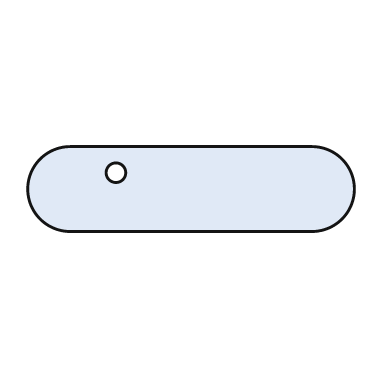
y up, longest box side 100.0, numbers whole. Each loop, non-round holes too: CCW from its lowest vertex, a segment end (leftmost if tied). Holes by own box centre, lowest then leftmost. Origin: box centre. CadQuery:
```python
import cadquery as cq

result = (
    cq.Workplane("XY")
    .moveTo(-37.0, -13.0)
    .lineTo(37.0, -13.0)
    .threePointArc((50.0, 0.0), (37.0, 13.0))
    .lineTo(-37.0, 13.0)
    .threePointArc((-50.0, 0.0), (-37.0, -13.0))
    .close()
    .moveTo(-23.0, 5.0)
    .circle(3.0)
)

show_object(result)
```